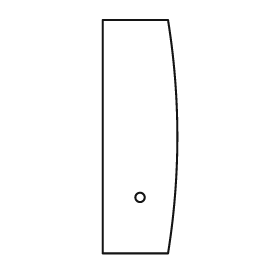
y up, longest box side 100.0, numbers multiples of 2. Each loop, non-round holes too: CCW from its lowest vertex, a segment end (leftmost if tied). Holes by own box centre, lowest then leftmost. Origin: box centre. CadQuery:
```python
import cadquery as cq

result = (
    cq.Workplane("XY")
    .moveTo(-16.0, -50.0)
    .lineTo(12.0, -50.0)
    .threePointArc((16.0, 0.0), (12.0, 50.0))
    .lineTo(-16.0, 50.0)
    .close()
    .moveTo(0.0, -26.0)
    .circle(2.0)
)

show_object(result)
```